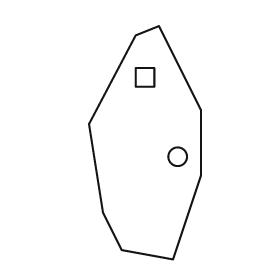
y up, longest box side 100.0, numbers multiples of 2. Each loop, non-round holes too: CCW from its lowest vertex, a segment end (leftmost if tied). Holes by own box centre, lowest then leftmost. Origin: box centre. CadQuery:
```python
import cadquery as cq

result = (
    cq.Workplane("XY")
    .moveTo(12.0, -50.0)
    .lineTo(24.0, -14.0)
    .lineTo(24.0, 14.0)
    .lineTo(6.0, 50.0)
    .lineTo(-4.0, 46.0)
    .lineTo(-24.0, 8.0)
    .lineTo(-18.0, -30.0)
    .lineTo(-10.0, -46.0)
    .close()
    .moveTo(14.0, -6.0)
    .circle(4.0)
    .moveTo(-4.0, 24.0)
    .lineTo(4.0, 24.0)
    .lineTo(4.0, 32.0)
    .lineTo(-4.0, 32.0)
    .close()
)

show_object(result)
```